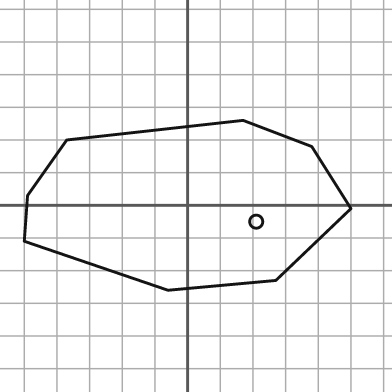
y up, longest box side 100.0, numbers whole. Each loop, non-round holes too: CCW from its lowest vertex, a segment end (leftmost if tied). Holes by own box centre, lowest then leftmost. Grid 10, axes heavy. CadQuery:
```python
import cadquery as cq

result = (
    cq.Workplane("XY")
    .moveTo(-6.0, -26.0)
    .lineTo(27.0, -23.0)
    .lineTo(50.0, -1.0)
    .lineTo(38.0, 18.0)
    .lineTo(17.0, 26.0)
    .lineTo(-37.0, 20.0)
    .lineTo(-49.0, 3.0)
    .lineTo(-50.0, -11.0)
    .close()
    .moveTo(21.0, -5.0)
    .circle(2.0)
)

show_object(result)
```